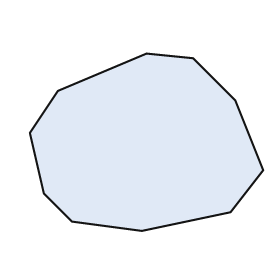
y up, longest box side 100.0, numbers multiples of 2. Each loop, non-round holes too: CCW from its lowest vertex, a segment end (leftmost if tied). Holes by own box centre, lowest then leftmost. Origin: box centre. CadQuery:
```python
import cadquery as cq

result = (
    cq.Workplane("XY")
    .moveTo(-2.0, -38.0)
    .lineTo(36.0, -30.0)
    .lineTo(50.0, -12.0)
    .lineTo(38.0, 18.0)
    .lineTo(20.0, 36.0)
    .lineTo(0.0, 38.0)
    .lineTo(-38.0, 22.0)
    .lineTo(-50.0, 4.0)
    .lineTo(-44.0, -22.0)
    .lineTo(-32.0, -34.0)
    .close()
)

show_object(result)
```